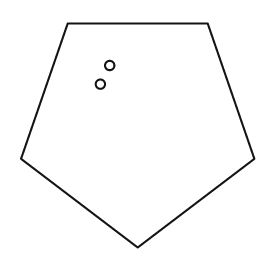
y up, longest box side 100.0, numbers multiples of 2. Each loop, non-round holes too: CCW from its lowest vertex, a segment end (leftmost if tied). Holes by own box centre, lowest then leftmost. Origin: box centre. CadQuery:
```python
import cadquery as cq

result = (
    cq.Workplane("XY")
    .moveTo(0.0, -48.0)
    .lineTo(50.0, -10.0)
    .lineTo(30.0, 48.0)
    .lineTo(-30.0, 48.0)
    .lineTo(-50.0, -10.0)
    .close()
    .moveTo(-16.0, 22.0)
    .circle(2.0)
    .moveTo(-12.0, 30.0)
    .circle(2.0)
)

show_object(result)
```